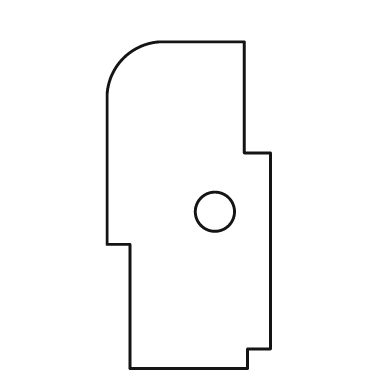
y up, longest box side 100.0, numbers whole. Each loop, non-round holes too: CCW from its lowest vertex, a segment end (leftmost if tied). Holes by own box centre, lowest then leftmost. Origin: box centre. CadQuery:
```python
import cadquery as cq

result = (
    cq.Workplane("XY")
    .moveTo(-18.0, -50.0)
    .lineTo(18.0, -50.0)
    .lineTo(18.0, -44.0)
    .lineTo(25.0, -44.0)
    .lineTo(25.0, 16.0)
    .lineTo(17.0, 16.0)
    .lineTo(17.0, 50.0)
    .lineTo(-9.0, 50.0)
    .threePointArc((-20.0, 45.0), (-25.0, 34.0))
    .lineTo(-25.0, -12.0)
    .lineTo(-18.0, -12.0)
    .close()
    .moveTo(8.0, -2.0)
    .circle(6.0)
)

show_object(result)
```